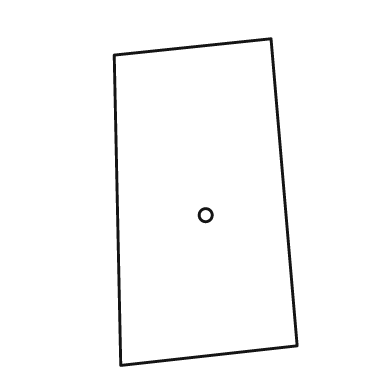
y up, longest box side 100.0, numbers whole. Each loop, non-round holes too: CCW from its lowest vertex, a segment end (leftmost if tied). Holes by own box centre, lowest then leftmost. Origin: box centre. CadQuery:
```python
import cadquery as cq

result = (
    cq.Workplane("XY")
    .moveTo(-26.0, -50.0)
    .lineTo(28.0, -44.0)
    .lineTo(20.0, 50.0)
    .lineTo(-28.0, 45.0)
    .close()
    .moveTo(0.0, -4.0)
    .circle(2.0)
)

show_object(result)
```